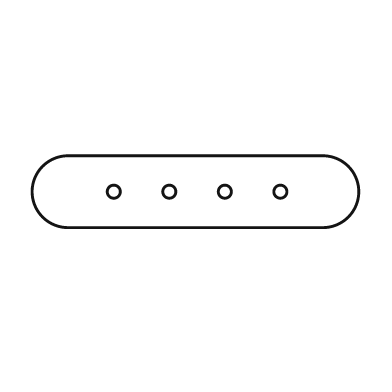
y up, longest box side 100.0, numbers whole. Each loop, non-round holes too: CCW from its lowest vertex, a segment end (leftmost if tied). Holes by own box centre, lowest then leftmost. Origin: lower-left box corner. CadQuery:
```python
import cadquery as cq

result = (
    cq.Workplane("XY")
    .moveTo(11.0, 0.0)
    .lineTo(89.0, 0.0)
    .threePointArc((100.0, 11.0), (89.0, 22.0))
    .lineTo(11.0, 22.0)
    .threePointArc((0.0, 11.0), (11.0, 0.0))
    .close()
    .moveTo(25.0, 11.0)
    .circle(2.0)
    .moveTo(42.0, 11.0)
    .circle(2.0)
    .moveTo(59.0, 11.0)
    .circle(2.0)
    .moveTo(76.0, 11.0)
    .circle(2.0)
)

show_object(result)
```